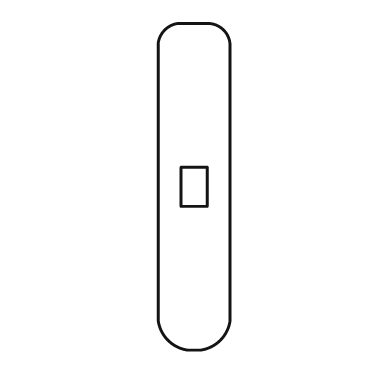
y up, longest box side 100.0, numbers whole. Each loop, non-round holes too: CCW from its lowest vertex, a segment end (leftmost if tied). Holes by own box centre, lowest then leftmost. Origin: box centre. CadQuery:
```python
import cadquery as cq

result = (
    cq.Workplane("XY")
    .moveTo(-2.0, -50.0)
    .lineTo(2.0, -50.0)
    .threePointArc((8.0, -47.0), (11.0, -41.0))
    .lineTo(11.0, 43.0)
    .threePointArc((9.0, 48.0), (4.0, 50.0))
    .lineTo(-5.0, 50.0)
    .threePointArc((-9.0, 48.0), (-11.0, 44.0))
    .lineTo(-11.0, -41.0)
    .threePointArc((-8.0, -47.0), (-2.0, -50.0))
    .close()
    .moveTo(-4.0, -6.0)
    .lineTo(4.0, -6.0)
    .lineTo(4.0, 6.0)
    .lineTo(-4.0, 6.0)
    .close()
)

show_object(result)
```